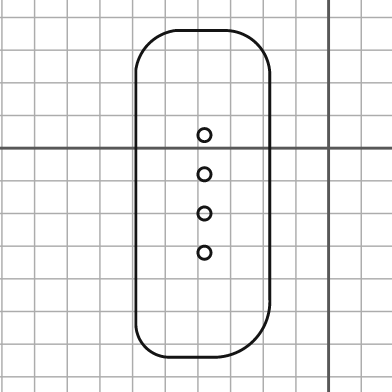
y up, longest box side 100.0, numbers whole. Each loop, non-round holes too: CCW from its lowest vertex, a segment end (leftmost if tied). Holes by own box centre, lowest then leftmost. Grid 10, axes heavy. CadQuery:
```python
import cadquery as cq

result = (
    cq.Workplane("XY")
    .moveTo(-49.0, -64.0)
    .lineTo(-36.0, -64.0)
    .threePointArc((-23.0, -59.0), (-18.0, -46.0))
    .lineTo(-18.0, 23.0)
    .threePointArc((-22.0, 32.0), (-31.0, 36.0))
    .lineTo(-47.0, 36.0)
    .threePointArc((-55.0, 32.0), (-59.0, 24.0))
    .lineTo(-59.0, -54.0)
    .threePointArc((-56.0, -61.0), (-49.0, -64.0))
    .close()
    .moveTo(-38.0, -32.0)
    .circle(2.0)
    .moveTo(-38.0, -20.0)
    .circle(2.0)
    .moveTo(-38.0, -8.0)
    .circle(2.0)
    .moveTo(-38.0, 4.0)
    .circle(2.0)
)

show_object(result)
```